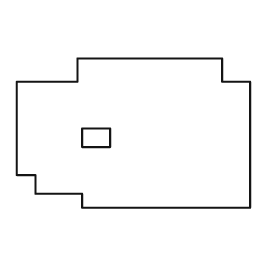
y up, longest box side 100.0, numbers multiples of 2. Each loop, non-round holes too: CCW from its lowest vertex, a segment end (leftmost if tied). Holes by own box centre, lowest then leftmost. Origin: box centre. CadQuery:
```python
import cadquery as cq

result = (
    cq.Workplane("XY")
    .moveTo(-22.0, -32.0)
    .lineTo(50.0, -32.0)
    .lineTo(50.0, 22.0)
    .lineTo(38.0, 22.0)
    .lineTo(38.0, 32.0)
    .lineTo(-24.0, 32.0)
    .lineTo(-24.0, 22.0)
    .lineTo(-50.0, 22.0)
    .lineTo(-50.0, -18.0)
    .lineTo(-42.0, -18.0)
    .lineTo(-42.0, -26.0)
    .lineTo(-22.0, -26.0)
    .close()
    .moveTo(-22.0, -6.0)
    .lineTo(-10.0, -6.0)
    .lineTo(-10.0, 2.0)
    .lineTo(-22.0, 2.0)
    .close()
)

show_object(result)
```